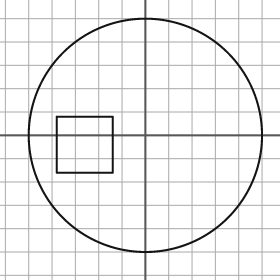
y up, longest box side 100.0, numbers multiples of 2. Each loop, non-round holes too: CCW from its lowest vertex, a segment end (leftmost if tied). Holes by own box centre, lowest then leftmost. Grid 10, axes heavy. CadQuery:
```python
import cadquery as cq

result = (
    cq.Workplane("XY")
    .moveTo(0.0, 0.0)
    .circle(50.0)
    .moveTo(-38.0, -16.0)
    .lineTo(-14.0, -16.0)
    .lineTo(-14.0, 8.0)
    .lineTo(-38.0, 8.0)
    .close()
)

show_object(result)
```